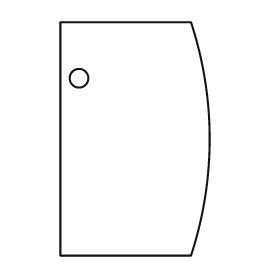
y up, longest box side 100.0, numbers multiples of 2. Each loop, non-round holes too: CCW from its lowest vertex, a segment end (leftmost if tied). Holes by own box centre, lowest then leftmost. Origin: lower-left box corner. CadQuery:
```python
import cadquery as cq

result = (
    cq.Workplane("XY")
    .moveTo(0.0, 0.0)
    .lineTo(56.0, 0.0)
    .threePointArc((64.0, 50.0), (56.0, 100.0))
    .lineTo(0.0, 100.0)
    .close()
    .moveTo(8.0, 76.0)
    .circle(4.0)
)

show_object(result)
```